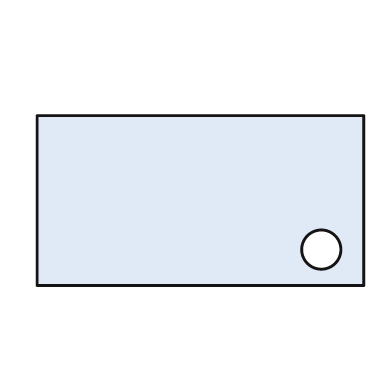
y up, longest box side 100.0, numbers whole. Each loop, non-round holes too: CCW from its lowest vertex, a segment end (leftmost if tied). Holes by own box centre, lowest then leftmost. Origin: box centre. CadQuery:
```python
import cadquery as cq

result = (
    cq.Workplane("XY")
    .moveTo(-50.0, -26.0)
    .lineTo(50.0, -26.0)
    .lineTo(50.0, 26.0)
    .lineTo(-50.0, 26.0)
    .close()
    .moveTo(37.0, -15.0)
    .circle(6.0)
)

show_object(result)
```